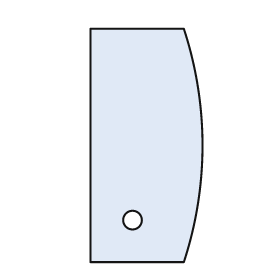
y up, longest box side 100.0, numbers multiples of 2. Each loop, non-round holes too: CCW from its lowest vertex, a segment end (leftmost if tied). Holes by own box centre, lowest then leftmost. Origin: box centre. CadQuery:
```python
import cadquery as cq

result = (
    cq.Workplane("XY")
    .moveTo(-24.0, -50.0)
    .lineTo(16.0, -50.0)
    .threePointArc((24.0, 0.0), (16.0, 50.0))
    .lineTo(-24.0, 50.0)
    .close()
    .moveTo(-6.0, -32.0)
    .circle(4.0)
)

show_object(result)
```